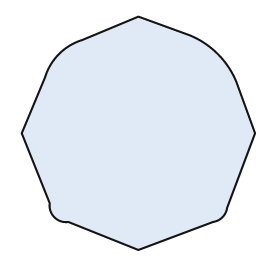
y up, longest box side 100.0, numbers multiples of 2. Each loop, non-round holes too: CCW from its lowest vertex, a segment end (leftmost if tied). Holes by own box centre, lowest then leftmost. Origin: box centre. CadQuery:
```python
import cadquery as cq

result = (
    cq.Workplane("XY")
    .moveTo(0.0, -50.0)
    .lineTo(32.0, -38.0)
    .threePointArc((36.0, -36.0), (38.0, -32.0))
    .lineTo(50.0, 0.0)
    .lineTo(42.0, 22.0)
    .threePointArc((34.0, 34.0), (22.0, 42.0))
    .lineTo(0.0, 50.0)
    .lineTo(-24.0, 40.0)
    .threePointArc((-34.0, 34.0), (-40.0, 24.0))
    .lineTo(-50.0, 0.0)
    .lineTo(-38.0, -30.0)
    .threePointArc((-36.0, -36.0), (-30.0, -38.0))
    .close()
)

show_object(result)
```